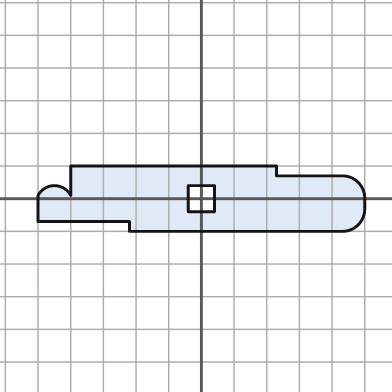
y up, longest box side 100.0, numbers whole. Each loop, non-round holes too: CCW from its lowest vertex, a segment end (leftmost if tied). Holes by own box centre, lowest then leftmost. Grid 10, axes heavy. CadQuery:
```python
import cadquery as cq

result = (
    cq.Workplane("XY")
    .moveTo(-22.0, -10.0)
    .lineTo(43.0, -10.0)
    .threePointArc((48.0, -8.0), (50.0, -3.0))
    .lineTo(50.0, 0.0)
    .threePointArc((48.0, 5.0), (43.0, 7.0))
    .lineTo(23.0, 7.0)
    .lineTo(23.0, 10.0)
    .lineTo(-40.0, 10.0)
    .lineTo(-40.0, 1.0)
    .threePointArc((-45.0, 4.0), (-50.0, 1.0))
    .lineTo(-50.0, -7.0)
    .lineTo(-22.0, -7.0)
    .close()
    .moveTo(-4.0, -4.0)
    .lineTo(4.0, -4.0)
    .lineTo(4.0, 4.0)
    .lineTo(-4.0, 4.0)
    .close()
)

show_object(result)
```